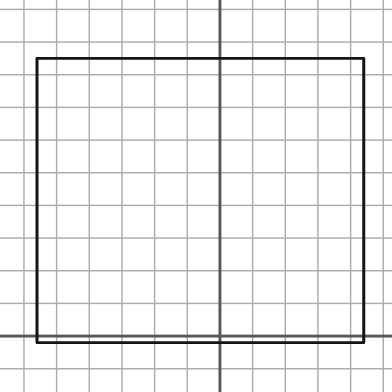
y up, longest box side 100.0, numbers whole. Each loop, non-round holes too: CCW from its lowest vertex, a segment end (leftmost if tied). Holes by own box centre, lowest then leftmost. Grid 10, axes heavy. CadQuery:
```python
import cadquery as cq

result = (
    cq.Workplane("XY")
    .moveTo(-56.0, -2.0)
    .lineTo(44.0, -2.0)
    .lineTo(44.0, 85.0)
    .lineTo(-56.0, 85.0)
    .close()
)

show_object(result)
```